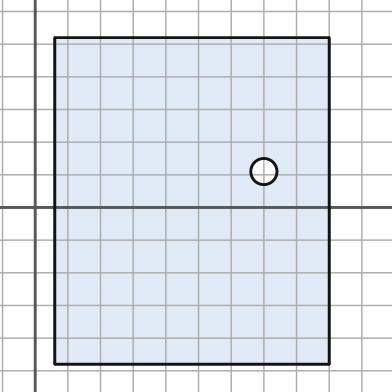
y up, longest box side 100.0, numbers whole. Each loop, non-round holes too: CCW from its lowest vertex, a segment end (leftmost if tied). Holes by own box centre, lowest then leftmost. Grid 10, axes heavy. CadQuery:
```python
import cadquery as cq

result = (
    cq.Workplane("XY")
    .moveTo(6.0, -48.0)
    .lineTo(90.0, -48.0)
    .lineTo(90.0, 52.0)
    .lineTo(6.0, 52.0)
    .close()
    .moveTo(70.0, 11.0)
    .circle(4.0)
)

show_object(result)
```